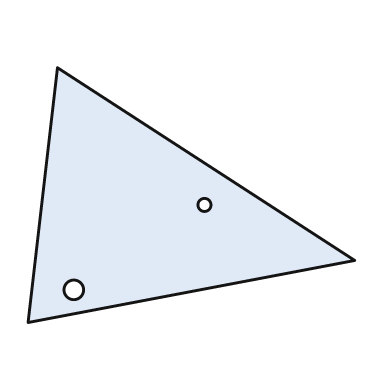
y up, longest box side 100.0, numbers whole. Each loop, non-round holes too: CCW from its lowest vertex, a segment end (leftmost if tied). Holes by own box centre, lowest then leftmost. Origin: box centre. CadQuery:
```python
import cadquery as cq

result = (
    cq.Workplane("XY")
    .moveTo(-50.0, -39.0)
    .lineTo(50.0, -20.0)
    .lineTo(-41.0, 39.0)
    .close()
    .moveTo(-36.0, -29.0)
    .circle(3.0)
    .moveTo(4.0, -3.0)
    .circle(2.0)
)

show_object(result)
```